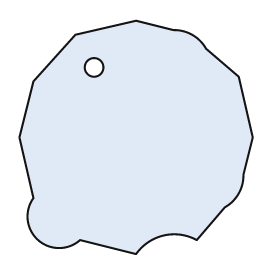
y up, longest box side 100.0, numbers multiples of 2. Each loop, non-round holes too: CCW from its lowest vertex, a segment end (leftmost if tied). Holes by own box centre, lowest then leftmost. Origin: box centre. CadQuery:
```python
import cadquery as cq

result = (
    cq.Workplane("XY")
    .moveTo(0.0, -50.0)
    .threePointArc((12.0, -42.0), (26.0, -44.0))
    .lineTo(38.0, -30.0)
    .threePointArc((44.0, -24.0), (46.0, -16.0))
    .lineTo(50.0, 0.0)
    .lineTo(44.0, 26.0)
    .lineTo(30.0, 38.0)
    .threePointArc((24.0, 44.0), (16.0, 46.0))
    .lineTo(0.0, 50.0)
    .lineTo(-26.0, 44.0)
    .lineTo(-44.0, 24.0)
    .lineTo(-50.0, 0.0)
    .lineTo(-44.0, -26.0)
    .threePointArc((-42.0, -44.0), (-24.0, -44.0))
    .close()
    .moveTo(-18.0, 30.0)
    .circle(4.0)
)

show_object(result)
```